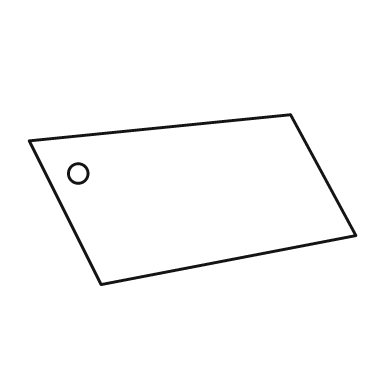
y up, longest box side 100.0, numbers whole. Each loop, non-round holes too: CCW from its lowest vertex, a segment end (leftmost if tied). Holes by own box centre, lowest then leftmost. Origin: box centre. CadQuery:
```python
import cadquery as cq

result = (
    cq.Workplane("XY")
    .moveTo(-28.0, -26.0)
    .lineTo(50.0, -11.0)
    .lineTo(30.0, 26.0)
    .lineTo(-50.0, 18.0)
    .close()
    .moveTo(-35.0, 8.0)
    .circle(3.0)
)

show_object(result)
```